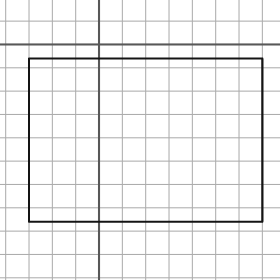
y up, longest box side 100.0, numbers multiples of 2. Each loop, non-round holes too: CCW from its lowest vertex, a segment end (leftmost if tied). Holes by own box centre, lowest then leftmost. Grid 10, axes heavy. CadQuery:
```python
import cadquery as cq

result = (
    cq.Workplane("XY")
    .moveTo(-30.0, -76.0)
    .lineTo(70.0, -76.0)
    .lineTo(70.0, -6.0)
    .lineTo(-30.0, -6.0)
    .close()
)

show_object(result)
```